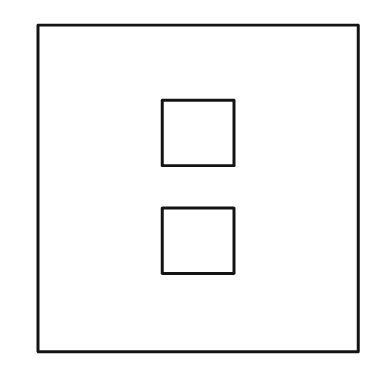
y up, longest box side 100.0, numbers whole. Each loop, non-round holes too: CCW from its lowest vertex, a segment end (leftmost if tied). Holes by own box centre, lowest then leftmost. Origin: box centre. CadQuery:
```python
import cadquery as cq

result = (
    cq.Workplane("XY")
    .moveTo(-49.0, -50.0)
    .lineTo(49.0, -50.0)
    .lineTo(49.0, 50.0)
    .lineTo(-49.0, 50.0)
    .close()
    .moveTo(-11.0, -26.0)
    .lineTo(11.0, -26.0)
    .lineTo(11.0, -6.0)
    .lineTo(-11.0, -6.0)
    .close()
    .moveTo(-11.0, 7.0)
    .lineTo(11.0, 7.0)
    .lineTo(11.0, 27.0)
    .lineTo(-11.0, 27.0)
    .close()
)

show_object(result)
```